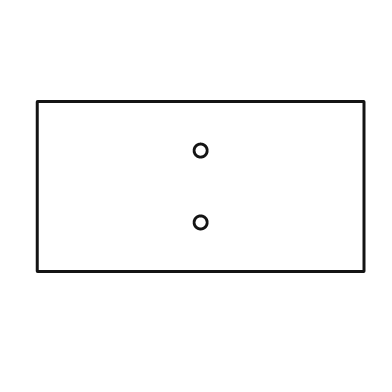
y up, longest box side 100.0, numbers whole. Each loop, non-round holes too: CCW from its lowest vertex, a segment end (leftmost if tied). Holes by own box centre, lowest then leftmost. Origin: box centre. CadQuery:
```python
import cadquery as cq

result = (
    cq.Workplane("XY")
    .moveTo(-50.0, -26.0)
    .lineTo(50.0, -26.0)
    .lineTo(50.0, 26.0)
    .lineTo(-50.0, 26.0)
    .close()
    .moveTo(0.0, -11.0)
    .circle(2.0)
    .moveTo(0.0, 11.0)
    .circle(2.0)
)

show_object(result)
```